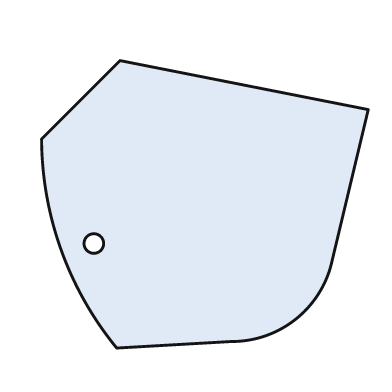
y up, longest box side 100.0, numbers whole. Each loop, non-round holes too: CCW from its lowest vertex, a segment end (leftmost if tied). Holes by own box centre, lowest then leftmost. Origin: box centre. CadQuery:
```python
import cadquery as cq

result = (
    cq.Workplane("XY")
    .moveTo(-27.0, -44.0)
    .lineTo(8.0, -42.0)
    .threePointArc((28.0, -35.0), (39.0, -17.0))
    .lineTo(50.0, 29.0)
    .lineTo(-26.0, 44.0)
    .lineTo(-50.0, 20.0)
    .threePointArc((-44.0, -14.0), (-27.0, -44.0))
    .close()
    .moveTo(-34.0, -12.0)
    .circle(3.0)
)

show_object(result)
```